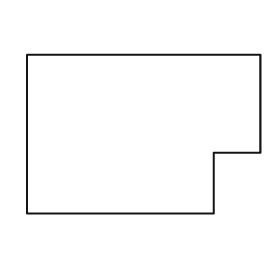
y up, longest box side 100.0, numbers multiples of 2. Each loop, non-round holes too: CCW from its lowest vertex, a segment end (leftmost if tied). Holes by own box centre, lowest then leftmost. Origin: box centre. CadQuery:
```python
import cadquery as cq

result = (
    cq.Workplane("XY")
    .moveTo(-50.0, -34.0)
    .lineTo(30.0, -34.0)
    .lineTo(30.0, -8.0)
    .lineTo(50.0, -8.0)
    .lineTo(50.0, 34.0)
    .lineTo(-50.0, 34.0)
    .close()
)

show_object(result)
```